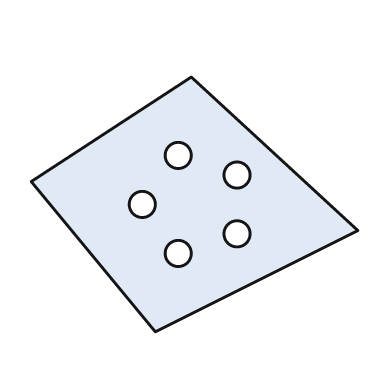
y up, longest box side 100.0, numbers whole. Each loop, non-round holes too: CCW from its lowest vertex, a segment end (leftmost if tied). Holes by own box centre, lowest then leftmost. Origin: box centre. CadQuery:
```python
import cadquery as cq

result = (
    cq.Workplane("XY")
    .moveTo(-12.0, -39.0)
    .lineTo(50.0, -8.0)
    .lineTo(-1.0, 39.0)
    .lineTo(-50.0, 7.0)
    .close()
    .moveTo(-5.0, -15.0)
    .circle(4.0)
    .moveTo(13.0, -9.0)
    .circle(4.0)
    .moveTo(-16.0, 0.0)
    .circle(4.0)
    .moveTo(13.0, 9.0)
    .circle(4.0)
    .moveTo(-5.0, 15.0)
    .circle(4.0)
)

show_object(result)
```